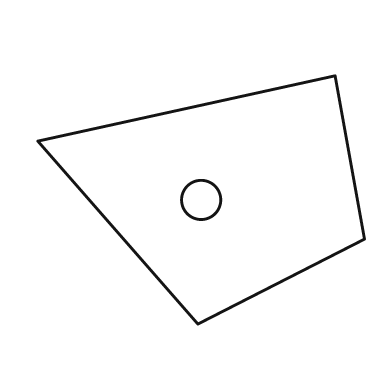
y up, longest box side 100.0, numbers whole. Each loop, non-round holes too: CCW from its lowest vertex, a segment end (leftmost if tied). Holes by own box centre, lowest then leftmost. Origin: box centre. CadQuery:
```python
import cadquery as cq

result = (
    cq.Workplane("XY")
    .moveTo(-1.0, -38.0)
    .lineTo(50.0, -12.0)
    .lineTo(41.0, 38.0)
    .lineTo(-50.0, 18.0)
    .close()
    .moveTo(0.0, 0.0)
    .circle(6.0)
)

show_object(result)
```